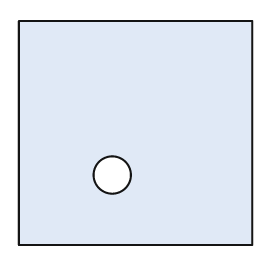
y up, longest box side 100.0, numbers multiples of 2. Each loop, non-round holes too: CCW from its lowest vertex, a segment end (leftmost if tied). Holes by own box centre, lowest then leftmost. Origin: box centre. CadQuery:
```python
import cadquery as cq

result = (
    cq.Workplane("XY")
    .moveTo(-50.0, -48.0)
    .lineTo(50.0, -48.0)
    .lineTo(50.0, 48.0)
    .lineTo(-50.0, 48.0)
    .close()
    .moveTo(-10.0, -18.0)
    .circle(8.0)
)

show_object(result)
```